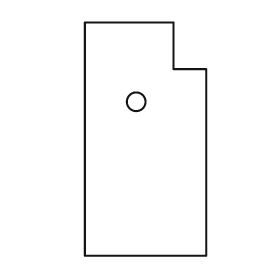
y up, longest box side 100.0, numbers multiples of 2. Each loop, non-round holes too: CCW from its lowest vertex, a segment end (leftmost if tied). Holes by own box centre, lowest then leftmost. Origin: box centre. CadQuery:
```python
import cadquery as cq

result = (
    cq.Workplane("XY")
    .moveTo(-26.0, -50.0)
    .lineTo(26.0, -50.0)
    .lineTo(26.0, 30.0)
    .lineTo(12.0, 30.0)
    .lineTo(12.0, 50.0)
    .lineTo(-26.0, 50.0)
    .close()
    .moveTo(-4.0, 16.0)
    .circle(4.0)
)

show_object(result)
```